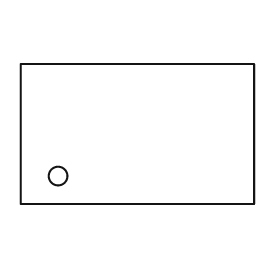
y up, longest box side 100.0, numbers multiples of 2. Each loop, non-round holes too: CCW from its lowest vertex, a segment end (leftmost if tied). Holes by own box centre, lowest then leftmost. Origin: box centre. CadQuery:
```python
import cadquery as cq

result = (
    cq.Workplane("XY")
    .moveTo(-50.0, -30.0)
    .lineTo(50.0, -30.0)
    .lineTo(50.0, 30.0)
    .lineTo(-50.0, 30.0)
    .close()
    .moveTo(-34.0, -18.0)
    .circle(4.0)
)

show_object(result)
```